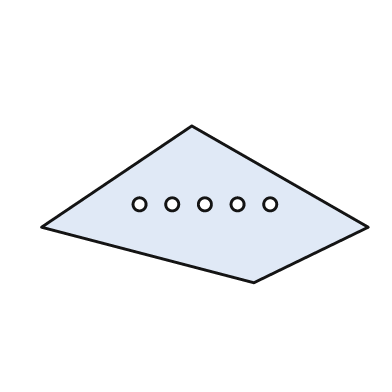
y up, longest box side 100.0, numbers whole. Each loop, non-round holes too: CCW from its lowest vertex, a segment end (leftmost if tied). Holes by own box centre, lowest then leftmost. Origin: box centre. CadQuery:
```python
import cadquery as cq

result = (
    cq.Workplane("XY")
    .moveTo(15.0, -24.0)
    .lineTo(50.0, -7.0)
    .lineTo(-4.0, 24.0)
    .lineTo(-50.0, -7.0)
    .close()
    .moveTo(-20.0, 0.0)
    .circle(2.0)
    .moveTo(-10.0, 0.0)
    .circle(2.0)
    .moveTo(0.0, 0.0)
    .circle(2.0)
    .moveTo(10.0, 0.0)
    .circle(2.0)
    .moveTo(20.0, 0.0)
    .circle(2.0)
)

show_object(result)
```